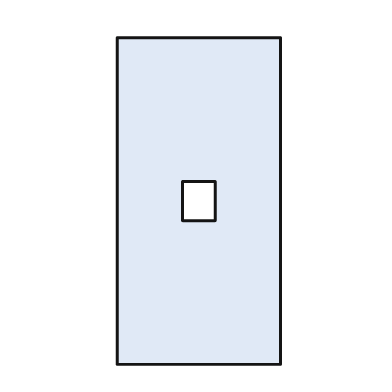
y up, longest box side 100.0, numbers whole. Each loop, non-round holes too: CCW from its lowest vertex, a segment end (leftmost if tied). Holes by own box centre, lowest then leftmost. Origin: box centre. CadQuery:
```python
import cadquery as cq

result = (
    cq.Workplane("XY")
    .moveTo(-25.0, -50.0)
    .lineTo(25.0, -50.0)
    .lineTo(25.0, 50.0)
    .lineTo(-25.0, 50.0)
    .close()
    .moveTo(-5.0, -6.0)
    .lineTo(5.0, -6.0)
    .lineTo(5.0, 6.0)
    .lineTo(-5.0, 6.0)
    .close()
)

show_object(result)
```